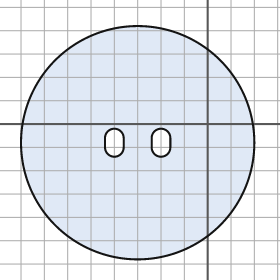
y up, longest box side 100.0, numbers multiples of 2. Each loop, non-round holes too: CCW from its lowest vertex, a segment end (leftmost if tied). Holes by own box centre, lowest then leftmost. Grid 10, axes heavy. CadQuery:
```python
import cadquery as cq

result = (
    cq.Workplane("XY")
    .moveTo(-30.0, -8.0)
    .circle(50.0)
    .moveTo(-44.0, -10.0)
    .threePointArc((-40.0, -14.0), (-36.0, -10.0))
    .lineTo(-36.0, -6.0)
    .threePointArc((-40.0, -2.0), (-44.0, -6.0))
    .close()
    .moveTo(-24.0, -10.0)
    .threePointArc((-20.0, -14.0), (-16.0, -10.0))
    .lineTo(-16.0, -6.0)
    .threePointArc((-20.0, -2.0), (-24.0, -6.0))
    .close()
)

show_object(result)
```